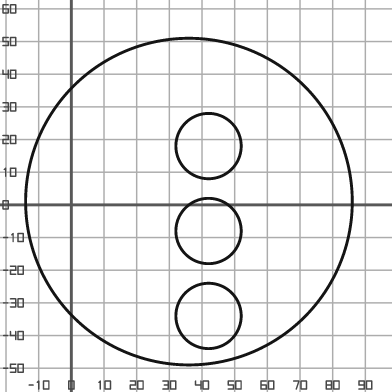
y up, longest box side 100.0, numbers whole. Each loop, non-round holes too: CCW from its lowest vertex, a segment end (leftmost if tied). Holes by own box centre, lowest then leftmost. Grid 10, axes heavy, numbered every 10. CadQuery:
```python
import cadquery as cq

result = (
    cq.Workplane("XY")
    .moveTo(36.0, 1.0)
    .circle(50.0)
    .moveTo(42.0, -34.0)
    .circle(10.0)
    .moveTo(42.0, -8.0)
    .circle(10.0)
    .moveTo(42.0, 18.0)
    .circle(10.0)
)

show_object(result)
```